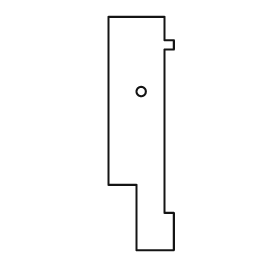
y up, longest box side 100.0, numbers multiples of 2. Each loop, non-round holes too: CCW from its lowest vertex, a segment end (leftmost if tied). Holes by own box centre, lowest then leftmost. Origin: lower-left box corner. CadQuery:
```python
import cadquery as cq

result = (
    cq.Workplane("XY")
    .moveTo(12.0, 0.0)
    .lineTo(28.0, 0.0)
    .lineTo(28.0, 16.0)
    .lineTo(24.0, 16.0)
    .lineTo(24.0, 86.0)
    .lineTo(28.0, 86.0)
    .lineTo(28.0, 90.0)
    .lineTo(24.0, 90.0)
    .lineTo(24.0, 100.0)
    .lineTo(0.0, 100.0)
    .lineTo(0.0, 28.0)
    .lineTo(12.0, 28.0)
    .close()
    .moveTo(14.0, 68.0)
    .circle(2.0)
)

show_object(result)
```